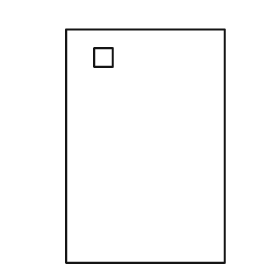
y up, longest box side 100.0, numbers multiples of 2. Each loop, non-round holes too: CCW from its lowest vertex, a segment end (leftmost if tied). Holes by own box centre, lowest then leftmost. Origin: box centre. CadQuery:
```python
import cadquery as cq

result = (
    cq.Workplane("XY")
    .moveTo(-34.0, -50.0)
    .lineTo(34.0, -50.0)
    .lineTo(34.0, 50.0)
    .lineTo(-34.0, 50.0)
    .close()
    .moveTo(-22.0, 34.0)
    .lineTo(-14.0, 34.0)
    .lineTo(-14.0, 42.0)
    .lineTo(-22.0, 42.0)
    .close()
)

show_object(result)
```